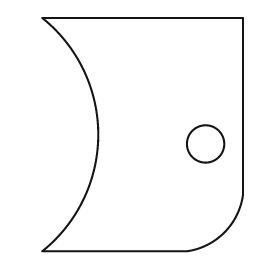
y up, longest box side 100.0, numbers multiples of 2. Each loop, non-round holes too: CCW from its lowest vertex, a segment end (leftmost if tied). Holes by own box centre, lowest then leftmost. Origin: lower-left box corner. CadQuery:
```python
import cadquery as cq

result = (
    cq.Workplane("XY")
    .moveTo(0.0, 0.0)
    .lineTo(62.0, 0.0)
    .threePointArc((78.0, 8.0), (86.0, 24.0))
    .lineTo(86.0, 100.0)
    .lineTo(0.0, 100.0)
    .threePointArc((24.0, 50.0), (0.0, 0.0))
    .close()
    .moveTo(70.0, 46.0)
    .circle(8.0)
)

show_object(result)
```